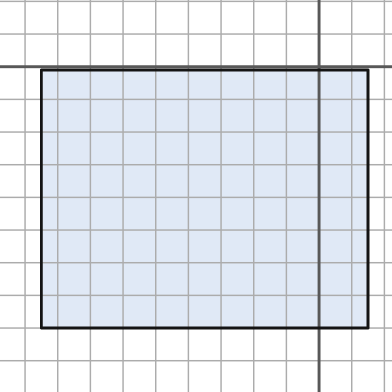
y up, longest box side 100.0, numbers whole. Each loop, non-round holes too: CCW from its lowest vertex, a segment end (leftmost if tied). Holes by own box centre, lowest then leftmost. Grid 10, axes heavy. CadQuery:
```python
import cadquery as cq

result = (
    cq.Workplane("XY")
    .moveTo(-85.0, -80.0)
    .lineTo(15.0, -80.0)
    .lineTo(15.0, -1.0)
    .lineTo(-85.0, -1.0)
    .close()
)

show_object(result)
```